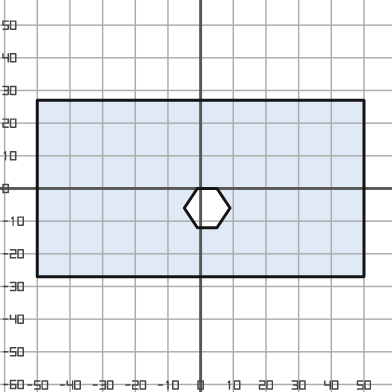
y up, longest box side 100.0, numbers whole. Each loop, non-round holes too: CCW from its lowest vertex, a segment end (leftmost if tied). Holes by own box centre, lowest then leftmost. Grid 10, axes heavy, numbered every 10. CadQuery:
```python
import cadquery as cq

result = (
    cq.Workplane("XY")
    .moveTo(-50.0, -27.0)
    .lineTo(50.0, -27.0)
    .lineTo(50.0, 27.0)
    .lineTo(-50.0, 27.0)
    .close()
    .moveTo(-1.0, -12.0)
    .lineTo(5.0, -12.0)
    .lineTo(9.0, -6.0)
    .lineTo(5.0, 0.0)
    .lineTo(-1.0, 0.0)
    .lineTo(-5.0, -6.0)
    .close()
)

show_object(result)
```